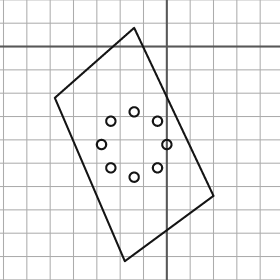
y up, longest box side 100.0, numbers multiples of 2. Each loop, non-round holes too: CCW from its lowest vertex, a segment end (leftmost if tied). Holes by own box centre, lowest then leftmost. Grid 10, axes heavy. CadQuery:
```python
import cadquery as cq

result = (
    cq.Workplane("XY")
    .moveTo(-18.0, -92.0)
    .lineTo(20.0, -64.0)
    .lineTo(-14.0, 8.0)
    .lineTo(-48.0, -22.0)
    .close()
    .moveTo(-14.0, -56.0)
    .circle(2.0)
    .moveTo(-24.0, -52.0)
    .circle(2.0)
    .moveTo(-4.0, -52.0)
    .circle(2.0)
    .moveTo(-28.0, -42.0)
    .circle(2.0)
    .moveTo(0.0, -42.0)
    .circle(2.0)
    .moveTo(-24.0, -32.0)
    .circle(2.0)
    .moveTo(-4.0, -32.0)
    .circle(2.0)
    .moveTo(-14.0, -28.0)
    .circle(2.0)
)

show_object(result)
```